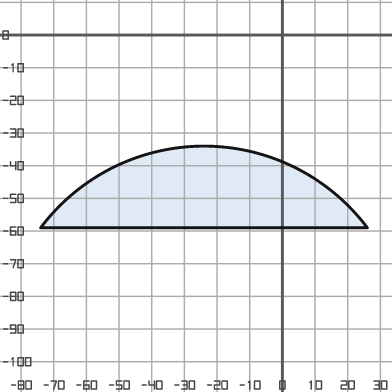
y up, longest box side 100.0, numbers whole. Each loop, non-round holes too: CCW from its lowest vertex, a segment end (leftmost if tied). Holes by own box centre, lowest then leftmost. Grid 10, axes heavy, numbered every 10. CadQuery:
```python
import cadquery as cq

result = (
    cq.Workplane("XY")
    .moveTo(-74.0, -59.0)
    .lineTo(26.0, -59.0)
    .threePointArc((-24.0, -34.0), (-74.0, -59.0))
    .close()
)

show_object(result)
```